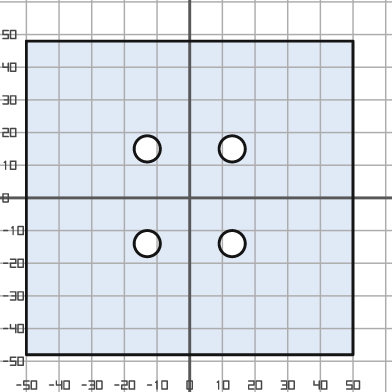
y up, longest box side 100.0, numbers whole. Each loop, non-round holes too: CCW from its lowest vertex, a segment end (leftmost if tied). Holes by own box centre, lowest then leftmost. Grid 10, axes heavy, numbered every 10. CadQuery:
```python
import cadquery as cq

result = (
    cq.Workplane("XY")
    .moveTo(-50.0, -48.0)
    .lineTo(50.0, -48.0)
    .lineTo(50.0, 48.0)
    .lineTo(-50.0, 48.0)
    .close()
    .moveTo(-13.0, -14.0)
    .circle(4.0)
    .moveTo(13.0, -14.0)
    .circle(4.0)
    .moveTo(-13.0, 15.0)
    .circle(4.0)
    .moveTo(13.0, 15.0)
    .circle(4.0)
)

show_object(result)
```